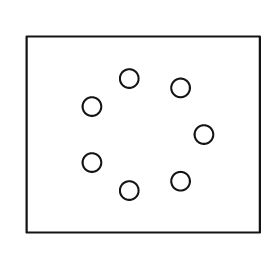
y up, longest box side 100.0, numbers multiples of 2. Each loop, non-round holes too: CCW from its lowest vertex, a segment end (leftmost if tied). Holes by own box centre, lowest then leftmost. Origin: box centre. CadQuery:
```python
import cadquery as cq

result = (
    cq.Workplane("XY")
    .moveTo(-50.0, -42.0)
    .lineTo(50.0, -42.0)
    .lineTo(50.0, 42.0)
    .lineTo(-50.0, 42.0)
    .close()
    .moveTo(-6.0, -24.0)
    .circle(4.0)
    .moveTo(16.0, -20.0)
    .circle(4.0)
    .moveTo(-22.0, -12.0)
    .circle(4.0)
    .moveTo(26.0, 0.0)
    .circle(4.0)
    .moveTo(-22.0, 12.0)
    .circle(4.0)
    .moveTo(16.0, 20.0)
    .circle(4.0)
    .moveTo(-6.0, 24.0)
    .circle(4.0)
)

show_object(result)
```